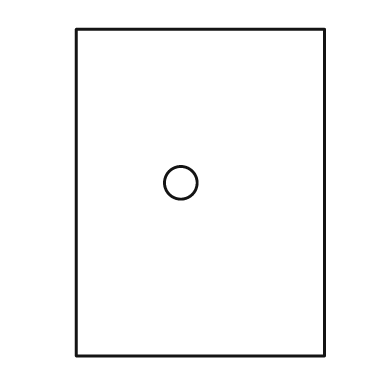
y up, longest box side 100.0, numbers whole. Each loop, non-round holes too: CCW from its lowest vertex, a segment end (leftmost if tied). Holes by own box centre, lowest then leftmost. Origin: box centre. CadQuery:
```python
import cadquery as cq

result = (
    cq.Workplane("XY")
    .moveTo(-38.0, -50.0)
    .lineTo(38.0, -50.0)
    .lineTo(38.0, 50.0)
    .lineTo(-38.0, 50.0)
    .close()
    .moveTo(-6.0, 3.0)
    .circle(5.0)
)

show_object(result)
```